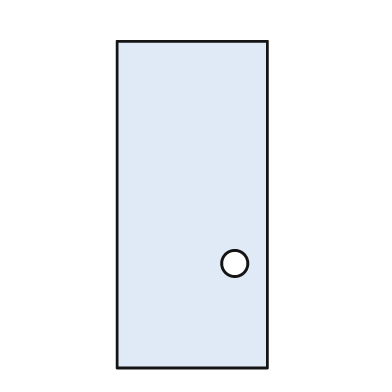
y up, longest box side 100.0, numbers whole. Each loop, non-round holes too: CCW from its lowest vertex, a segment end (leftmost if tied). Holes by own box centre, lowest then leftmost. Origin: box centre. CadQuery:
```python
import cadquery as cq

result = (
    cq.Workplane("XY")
    .moveTo(-23.0, -50.0)
    .lineTo(23.0, -50.0)
    .lineTo(23.0, 50.0)
    .lineTo(-23.0, 50.0)
    .close()
    .moveTo(13.0, -18.0)
    .circle(4.0)
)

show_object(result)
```